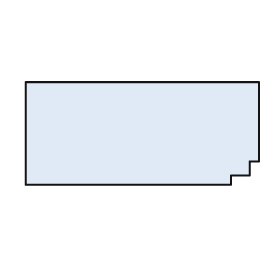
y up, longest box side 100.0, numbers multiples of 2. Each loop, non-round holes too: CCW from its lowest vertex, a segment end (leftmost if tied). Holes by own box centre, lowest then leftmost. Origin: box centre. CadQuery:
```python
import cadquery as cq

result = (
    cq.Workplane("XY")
    .moveTo(-50.0, -22.0)
    .lineTo(38.0, -22.0)
    .lineTo(38.0, -18.0)
    .lineTo(46.0, -18.0)
    .lineTo(46.0, -12.0)
    .lineTo(50.0, -12.0)
    .lineTo(50.0, 22.0)
    .lineTo(-50.0, 22.0)
    .close()
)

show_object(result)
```